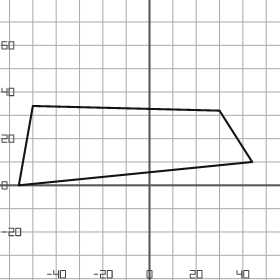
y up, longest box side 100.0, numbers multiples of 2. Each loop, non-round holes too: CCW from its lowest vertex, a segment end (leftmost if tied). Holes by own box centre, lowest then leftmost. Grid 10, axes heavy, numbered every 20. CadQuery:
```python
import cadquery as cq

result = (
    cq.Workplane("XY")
    .moveTo(-56.0, 0.0)
    .lineTo(44.0, 10.0)
    .lineTo(30.0, 32.0)
    .lineTo(-50.0, 34.0)
    .close()
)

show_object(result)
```